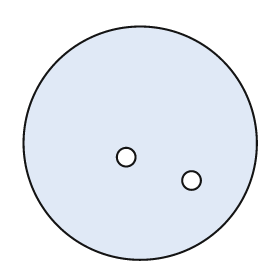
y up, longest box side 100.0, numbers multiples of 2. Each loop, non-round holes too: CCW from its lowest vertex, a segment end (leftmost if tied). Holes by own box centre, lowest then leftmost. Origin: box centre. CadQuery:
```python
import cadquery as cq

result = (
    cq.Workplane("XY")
    .moveTo(0.0, 0.0)
    .circle(50.0)
    .moveTo(22.0, -16.0)
    .circle(4.0)
    .moveTo(-6.0, -6.0)
    .circle(4.0)
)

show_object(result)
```